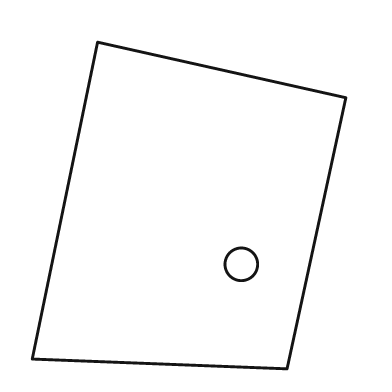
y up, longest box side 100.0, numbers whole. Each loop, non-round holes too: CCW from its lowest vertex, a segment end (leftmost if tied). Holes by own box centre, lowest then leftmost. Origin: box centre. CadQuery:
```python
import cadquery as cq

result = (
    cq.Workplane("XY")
    .moveTo(30.0, -50.0)
    .lineTo(48.0, 33.0)
    .lineTo(-28.0, 50.0)
    .lineTo(-48.0, -47.0)
    .close()
    .moveTo(16.0, -18.0)
    .circle(5.0)
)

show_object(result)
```